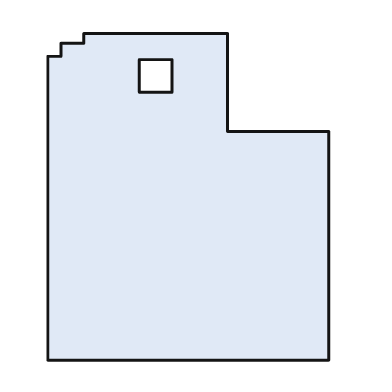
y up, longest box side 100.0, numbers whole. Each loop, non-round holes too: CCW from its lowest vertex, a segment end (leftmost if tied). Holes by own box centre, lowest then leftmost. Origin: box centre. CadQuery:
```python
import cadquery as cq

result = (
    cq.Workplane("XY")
    .moveTo(-43.0, -50.0)
    .lineTo(43.0, -50.0)
    .lineTo(43.0, 20.0)
    .lineTo(12.0, 20.0)
    .lineTo(12.0, 50.0)
    .lineTo(-32.0, 50.0)
    .lineTo(-32.0, 47.0)
    .lineTo(-39.0, 47.0)
    .lineTo(-39.0, 43.0)
    .lineTo(-43.0, 43.0)
    .close()
    .moveTo(-15.0, 32.0)
    .lineTo(-5.0, 32.0)
    .lineTo(-5.0, 42.0)
    .lineTo(-15.0, 42.0)
    .close()
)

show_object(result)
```